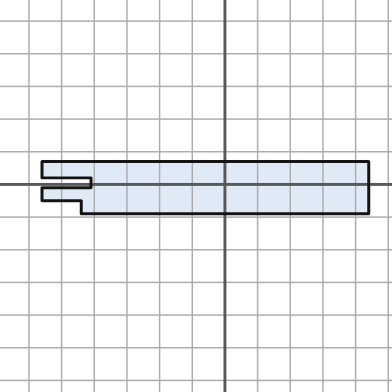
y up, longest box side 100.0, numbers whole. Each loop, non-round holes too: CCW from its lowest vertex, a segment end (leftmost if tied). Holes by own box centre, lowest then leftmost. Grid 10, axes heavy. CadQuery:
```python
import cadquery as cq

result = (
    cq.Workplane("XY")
    .moveTo(-44.0, -9.0)
    .lineTo(44.0, -9.0)
    .lineTo(44.0, 7.0)
    .lineTo(-56.0, 7.0)
    .lineTo(-56.0, 2.0)
    .lineTo(-41.0, 2.0)
    .lineTo(-41.0, -1.0)
    .lineTo(-56.0, -1.0)
    .lineTo(-56.0, -5.0)
    .lineTo(-44.0, -5.0)
    .close()
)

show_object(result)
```